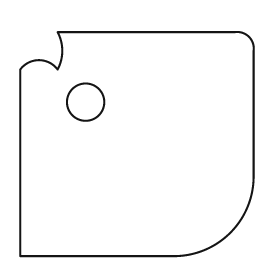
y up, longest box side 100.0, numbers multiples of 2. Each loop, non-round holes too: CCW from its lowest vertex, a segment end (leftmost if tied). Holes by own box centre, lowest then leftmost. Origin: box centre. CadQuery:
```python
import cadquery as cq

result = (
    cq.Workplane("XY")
    .moveTo(-50.0, -48.0)
    .lineTo(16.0, -48.0)
    .threePointArc((40.0, -38.0), (50.0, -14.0))
    .lineTo(50.0, 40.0)
    .threePointArc((48.0, 46.0), (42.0, 48.0))
    .lineTo(-34.0, 48.0)
    .threePointArc((-32.0, 40.0), (-34.0, 32.0))
    .threePointArc((-42.0, 36.0), (-50.0, 32.0))
    .close()
    .moveTo(-22.0, 18.0)
    .circle(8.0)
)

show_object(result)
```